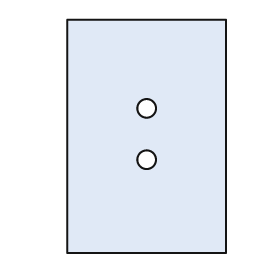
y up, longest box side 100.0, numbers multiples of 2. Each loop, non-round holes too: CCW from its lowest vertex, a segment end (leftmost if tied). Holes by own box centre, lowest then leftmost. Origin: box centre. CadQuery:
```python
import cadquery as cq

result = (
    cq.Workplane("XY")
    .moveTo(-34.0, -50.0)
    .lineTo(34.0, -50.0)
    .lineTo(34.0, 50.0)
    .lineTo(-34.0, 50.0)
    .close()
    .moveTo(0.0, -10.0)
    .circle(4.0)
    .moveTo(0.0, 12.0)
    .circle(4.0)
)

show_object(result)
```